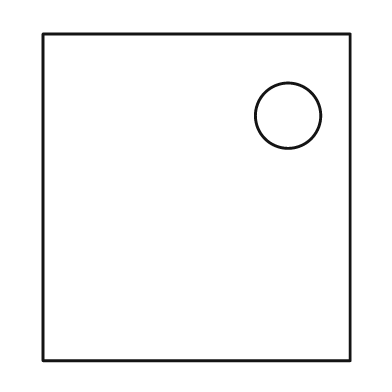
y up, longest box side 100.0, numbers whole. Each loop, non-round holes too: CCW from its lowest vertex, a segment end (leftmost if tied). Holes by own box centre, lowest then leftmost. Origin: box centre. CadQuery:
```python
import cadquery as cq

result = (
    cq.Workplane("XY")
    .moveTo(-47.0, -50.0)
    .lineTo(47.0, -50.0)
    .lineTo(47.0, 50.0)
    .lineTo(-47.0, 50.0)
    .close()
    .moveTo(28.0, 25.0)
    .circle(10.0)
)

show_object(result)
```